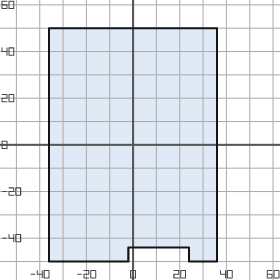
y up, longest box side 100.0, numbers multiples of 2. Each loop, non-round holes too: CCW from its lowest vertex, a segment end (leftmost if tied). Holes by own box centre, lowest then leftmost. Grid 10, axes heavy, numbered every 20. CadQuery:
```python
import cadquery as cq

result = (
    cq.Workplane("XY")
    .moveTo(-36.0, -50.0)
    .lineTo(-2.0, -50.0)
    .lineTo(-2.0, -44.0)
    .lineTo(24.0, -44.0)
    .lineTo(24.0, -50.0)
    .lineTo(36.0, -50.0)
    .lineTo(36.0, 50.0)
    .lineTo(-36.0, 50.0)
    .close()
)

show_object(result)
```